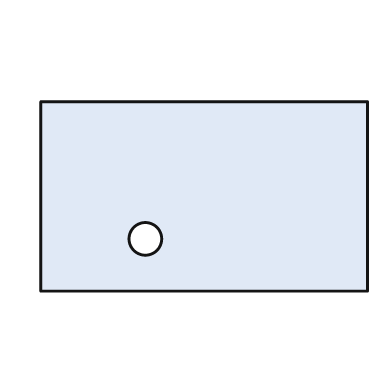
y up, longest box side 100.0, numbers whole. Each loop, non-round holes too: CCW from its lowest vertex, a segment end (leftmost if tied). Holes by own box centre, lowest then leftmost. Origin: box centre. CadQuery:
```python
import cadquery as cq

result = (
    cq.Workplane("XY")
    .moveTo(-50.0, -29.0)
    .lineTo(50.0, -29.0)
    .lineTo(50.0, 29.0)
    .lineTo(-50.0, 29.0)
    .close()
    .moveTo(-18.0, -13.0)
    .circle(5.0)
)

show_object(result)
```